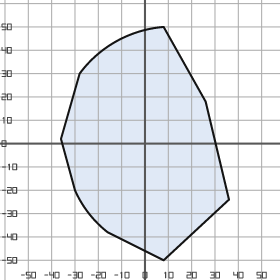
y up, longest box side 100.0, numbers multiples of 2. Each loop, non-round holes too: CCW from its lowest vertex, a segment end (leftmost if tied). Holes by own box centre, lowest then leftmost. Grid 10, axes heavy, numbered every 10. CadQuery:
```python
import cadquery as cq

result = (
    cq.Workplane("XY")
    .moveTo(8.0, -50.0)
    .lineTo(36.0, -24.0)
    .lineTo(26.0, 18.0)
    .lineTo(8.0, 50.0)
    .threePointArc((-12.0, 44.0), (-28.0, 30.0))
    .lineTo(-36.0, 2.0)
    .lineTo(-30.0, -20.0)
    .threePointArc((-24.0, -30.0), (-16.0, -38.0))
    .close()
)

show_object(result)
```